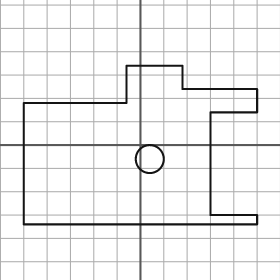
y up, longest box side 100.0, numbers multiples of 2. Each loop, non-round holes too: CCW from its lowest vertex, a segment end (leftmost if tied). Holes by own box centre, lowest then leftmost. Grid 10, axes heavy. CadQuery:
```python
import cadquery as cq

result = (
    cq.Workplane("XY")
    .moveTo(-50.0, -34.0)
    .lineTo(50.0, -34.0)
    .lineTo(50.0, -30.0)
    .lineTo(30.0, -30.0)
    .lineTo(30.0, 14.0)
    .lineTo(50.0, 14.0)
    .lineTo(50.0, 24.0)
    .lineTo(18.0, 24.0)
    .lineTo(18.0, 34.0)
    .lineTo(-6.0, 34.0)
    .lineTo(-6.0, 18.0)
    .lineTo(-50.0, 18.0)
    .close()
    .moveTo(4.0, -6.0)
    .circle(6.0)
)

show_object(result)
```